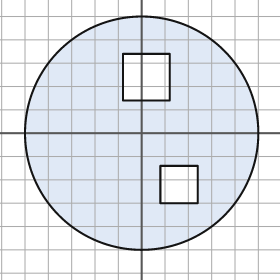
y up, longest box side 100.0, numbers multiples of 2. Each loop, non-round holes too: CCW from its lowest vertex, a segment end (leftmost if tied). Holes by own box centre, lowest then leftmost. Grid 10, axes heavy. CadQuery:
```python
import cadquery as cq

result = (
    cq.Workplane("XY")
    .moveTo(0.0, 0.0)
    .circle(50.0)
    .moveTo(8.0, -30.0)
    .lineTo(24.0, -30.0)
    .lineTo(24.0, -14.0)
    .lineTo(8.0, -14.0)
    .close()
    .moveTo(-8.0, 14.0)
    .lineTo(12.0, 14.0)
    .lineTo(12.0, 34.0)
    .lineTo(-8.0, 34.0)
    .close()
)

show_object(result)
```